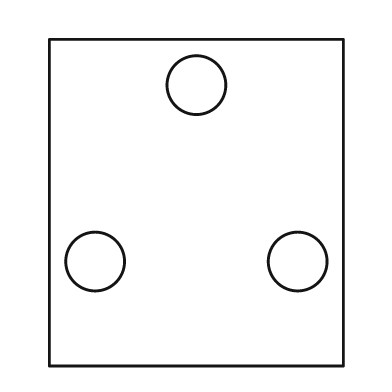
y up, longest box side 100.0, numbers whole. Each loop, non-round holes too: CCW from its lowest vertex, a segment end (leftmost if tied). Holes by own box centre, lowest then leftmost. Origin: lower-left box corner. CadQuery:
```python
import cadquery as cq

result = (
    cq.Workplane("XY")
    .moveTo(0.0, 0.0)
    .lineTo(90.0, 0.0)
    .lineTo(90.0, 100.0)
    .lineTo(0.0, 100.0)
    .close()
    .moveTo(14.0, 32.0)
    .circle(9.0)
    .moveTo(76.0, 32.0)
    .circle(9.0)
    .moveTo(45.0, 86.0)
    .circle(9.0)
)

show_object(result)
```